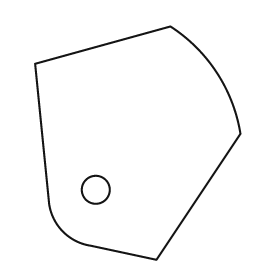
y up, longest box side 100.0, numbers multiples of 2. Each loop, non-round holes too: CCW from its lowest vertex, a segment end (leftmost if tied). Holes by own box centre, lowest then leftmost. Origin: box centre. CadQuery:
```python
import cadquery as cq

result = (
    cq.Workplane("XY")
    .moveTo(8.0, -50.0)
    .lineTo(44.0, 4.0)
    .threePointArc((34.0, 30.0), (14.0, 50.0))
    .lineTo(-44.0, 34.0)
    .lineTo(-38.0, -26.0)
    .threePointArc((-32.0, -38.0), (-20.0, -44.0))
    .close()
    .moveTo(-18.0, -20.0)
    .circle(6.0)
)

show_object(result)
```